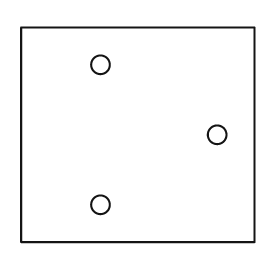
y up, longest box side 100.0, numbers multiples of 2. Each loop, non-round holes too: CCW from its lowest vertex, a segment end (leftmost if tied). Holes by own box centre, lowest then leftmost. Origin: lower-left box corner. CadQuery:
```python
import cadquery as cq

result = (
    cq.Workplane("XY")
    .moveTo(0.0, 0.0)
    .lineTo(100.0, 0.0)
    .lineTo(100.0, 92.0)
    .lineTo(0.0, 92.0)
    .close()
    .moveTo(34.0, 16.0)
    .circle(4.0)
    .moveTo(84.0, 46.0)
    .circle(4.0)
    .moveTo(34.0, 76.0)
    .circle(4.0)
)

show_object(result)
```